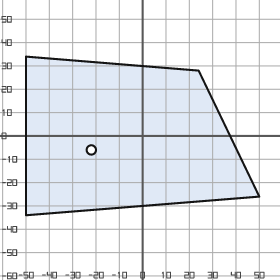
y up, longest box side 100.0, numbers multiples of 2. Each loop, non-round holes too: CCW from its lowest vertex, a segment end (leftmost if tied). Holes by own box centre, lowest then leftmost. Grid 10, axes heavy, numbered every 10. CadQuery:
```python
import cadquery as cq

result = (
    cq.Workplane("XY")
    .moveTo(-50.0, -34.0)
    .lineTo(50.0, -26.0)
    .lineTo(24.0, 28.0)
    .lineTo(-50.0, 34.0)
    .close()
    .moveTo(-22.0, -6.0)
    .circle(2.0)
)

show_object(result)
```